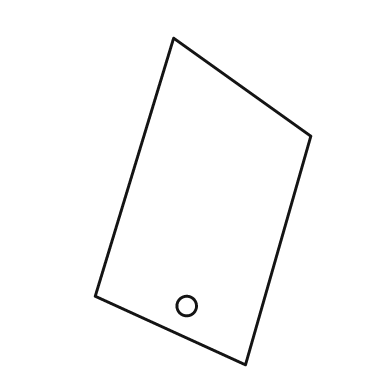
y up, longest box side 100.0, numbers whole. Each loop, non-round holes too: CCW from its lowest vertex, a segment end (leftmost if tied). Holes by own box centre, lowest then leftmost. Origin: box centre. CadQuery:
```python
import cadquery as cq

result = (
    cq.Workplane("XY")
    .moveTo(13.0, -50.0)
    .lineTo(33.0, 20.0)
    .lineTo(-9.0, 50.0)
    .lineTo(-33.0, -29.0)
    .close()
    .moveTo(-5.0, -32.0)
    .circle(3.0)
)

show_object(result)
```